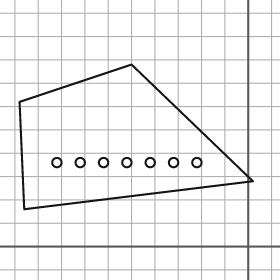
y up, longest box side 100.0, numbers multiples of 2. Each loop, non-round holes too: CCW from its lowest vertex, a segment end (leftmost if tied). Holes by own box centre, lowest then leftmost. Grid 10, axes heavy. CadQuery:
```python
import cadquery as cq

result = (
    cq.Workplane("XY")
    .moveTo(-96.0, 16.0)
    .lineTo(2.0, 28.0)
    .lineTo(-50.0, 78.0)
    .lineTo(-98.0, 62.0)
    .close()
    .moveTo(-82.0, 36.0)
    .circle(2.0)
    .moveTo(-72.0, 36.0)
    .circle(2.0)
    .moveTo(-62.0, 36.0)
    .circle(2.0)
    .moveTo(-52.0, 36.0)
    .circle(2.0)
    .moveTo(-42.0, 36.0)
    .circle(2.0)
    .moveTo(-32.0, 36.0)
    .circle(2.0)
    .moveTo(-22.0, 36.0)
    .circle(2.0)
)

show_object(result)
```